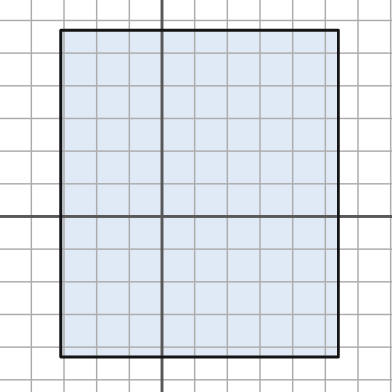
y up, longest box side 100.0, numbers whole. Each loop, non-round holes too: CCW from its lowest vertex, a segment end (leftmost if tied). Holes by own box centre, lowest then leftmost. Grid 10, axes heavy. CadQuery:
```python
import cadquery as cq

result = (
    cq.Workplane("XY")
    .moveTo(-31.0, -43.0)
    .lineTo(54.0, -43.0)
    .lineTo(54.0, 57.0)
    .lineTo(-31.0, 57.0)
    .close()
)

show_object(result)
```